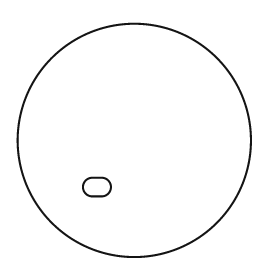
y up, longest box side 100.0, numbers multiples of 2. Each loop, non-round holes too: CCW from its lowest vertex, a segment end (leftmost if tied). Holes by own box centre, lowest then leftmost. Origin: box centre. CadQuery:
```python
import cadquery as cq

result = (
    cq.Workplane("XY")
    .moveTo(0.0, 0.0)
    .circle(50.0)
    .moveTo(-18.0, -24.0)
    .lineTo(-14.0, -24.0)
    .threePointArc((-10.0, -20.0), (-14.0, -16.0))
    .lineTo(-18.0, -16.0)
    .threePointArc((-22.0, -20.0), (-18.0, -24.0))
    .close()
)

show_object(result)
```